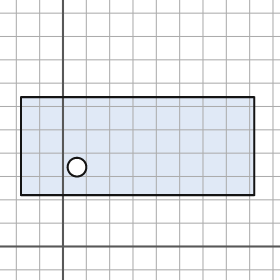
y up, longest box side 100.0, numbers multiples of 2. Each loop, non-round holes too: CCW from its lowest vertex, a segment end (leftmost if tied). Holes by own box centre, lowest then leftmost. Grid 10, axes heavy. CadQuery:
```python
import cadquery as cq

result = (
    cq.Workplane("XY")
    .moveTo(-18.0, 22.0)
    .lineTo(82.0, 22.0)
    .lineTo(82.0, 64.0)
    .lineTo(-18.0, 64.0)
    .close()
    .moveTo(6.0, 34.0)
    .circle(4.0)
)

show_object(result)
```